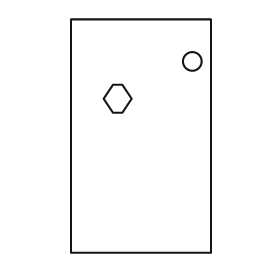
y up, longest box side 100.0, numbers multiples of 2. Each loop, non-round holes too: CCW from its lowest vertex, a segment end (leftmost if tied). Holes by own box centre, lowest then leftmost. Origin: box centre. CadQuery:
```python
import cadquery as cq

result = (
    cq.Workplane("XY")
    .moveTo(-30.0, -50.0)
    .lineTo(30.0, -50.0)
    .lineTo(30.0, 50.0)
    .lineTo(-30.0, 50.0)
    .close()
    .moveTo(-12.0, 10.0)
    .lineTo(-8.0, 10.0)
    .lineTo(-4.0, 16.0)
    .lineTo(-8.0, 22.0)
    .lineTo(-12.0, 22.0)
    .lineTo(-16.0, 16.0)
    .close()
    .moveTo(22.0, 32.0)
    .circle(4.0)
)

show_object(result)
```